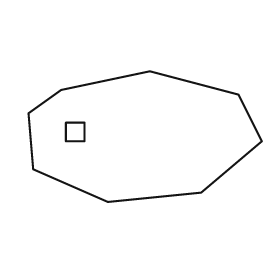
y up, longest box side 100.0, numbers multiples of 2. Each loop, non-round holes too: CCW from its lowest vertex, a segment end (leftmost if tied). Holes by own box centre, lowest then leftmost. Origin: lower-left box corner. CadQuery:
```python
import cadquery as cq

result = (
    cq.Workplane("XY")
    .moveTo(34.0, 0.0)
    .lineTo(74.0, 4.0)
    .lineTo(100.0, 26.0)
    .lineTo(90.0, 46.0)
    .lineTo(52.0, 56.0)
    .lineTo(14.0, 48.0)
    .lineTo(0.0, 38.0)
    .lineTo(2.0, 14.0)
    .close()
    .moveTo(16.0, 26.0)
    .lineTo(24.0, 26.0)
    .lineTo(24.0, 34.0)
    .lineTo(16.0, 34.0)
    .close()
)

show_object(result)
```